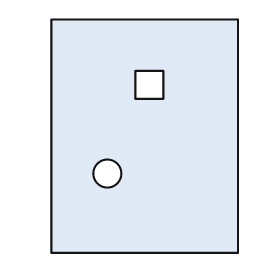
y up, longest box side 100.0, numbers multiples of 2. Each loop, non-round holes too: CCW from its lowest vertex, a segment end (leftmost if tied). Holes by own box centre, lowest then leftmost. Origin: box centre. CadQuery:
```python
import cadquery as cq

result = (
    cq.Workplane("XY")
    .moveTo(-40.0, -50.0)
    .lineTo(40.0, -50.0)
    .lineTo(40.0, 50.0)
    .lineTo(-40.0, 50.0)
    .close()
    .moveTo(-16.0, -16.0)
    .circle(6.0)
    .moveTo(-4.0, 16.0)
    .lineTo(8.0, 16.0)
    .lineTo(8.0, 28.0)
    .lineTo(-4.0, 28.0)
    .close()
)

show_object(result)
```